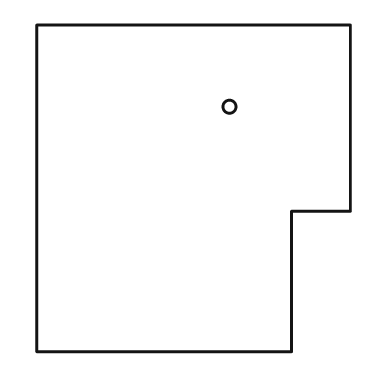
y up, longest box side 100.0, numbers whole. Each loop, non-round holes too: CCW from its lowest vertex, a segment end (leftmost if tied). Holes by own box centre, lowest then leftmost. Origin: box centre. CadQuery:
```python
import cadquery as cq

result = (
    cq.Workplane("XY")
    .moveTo(-48.0, -50.0)
    .lineTo(30.0, -50.0)
    .lineTo(30.0, -7.0)
    .lineTo(48.0, -7.0)
    .lineTo(48.0, 50.0)
    .lineTo(-48.0, 50.0)
    .close()
    .moveTo(11.0, 25.0)
    .circle(2.0)
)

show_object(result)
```